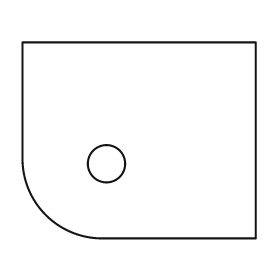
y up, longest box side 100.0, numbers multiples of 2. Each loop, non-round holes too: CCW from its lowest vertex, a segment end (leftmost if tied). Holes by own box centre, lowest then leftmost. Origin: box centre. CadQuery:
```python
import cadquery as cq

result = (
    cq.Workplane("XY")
    .moveTo(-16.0, -42.0)
    .lineTo(50.0, -42.0)
    .lineTo(50.0, 42.0)
    .lineTo(-50.0, 42.0)
    .lineTo(-50.0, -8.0)
    .threePointArc((-40.0, -32.0), (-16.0, -42.0))
    .close()
    .moveTo(-14.0, -10.0)
    .circle(8.0)
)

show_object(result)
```